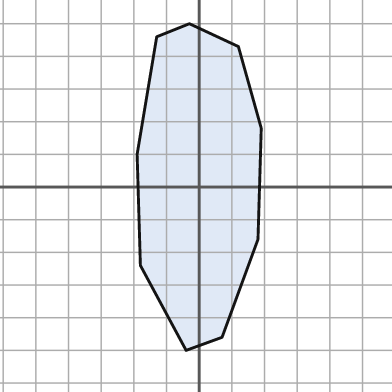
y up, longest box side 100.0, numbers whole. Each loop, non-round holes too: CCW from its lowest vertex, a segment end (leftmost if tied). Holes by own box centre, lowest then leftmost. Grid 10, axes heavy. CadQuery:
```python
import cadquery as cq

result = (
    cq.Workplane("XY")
    .moveTo(-4.0, -50.0)
    .lineTo(7.0, -46.0)
    .lineTo(18.0, -16.0)
    .lineTo(19.0, 18.0)
    .lineTo(12.0, 43.0)
    .lineTo(-3.0, 50.0)
    .lineTo(-13.0, 46.0)
    .lineTo(-19.0, 10.0)
    .lineTo(-18.0, -24.0)
    .close()
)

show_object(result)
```